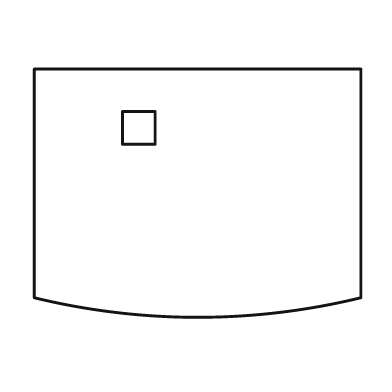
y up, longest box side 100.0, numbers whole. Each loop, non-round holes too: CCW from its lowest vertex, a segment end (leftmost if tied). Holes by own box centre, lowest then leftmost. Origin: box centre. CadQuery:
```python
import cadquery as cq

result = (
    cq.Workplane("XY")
    .moveTo(-50.0, -32.0)
    .threePointArc((0.0, -38.0), (50.0, -32.0))
    .lineTo(50.0, 38.0)
    .lineTo(-50.0, 38.0)
    .close()
    .moveTo(-23.0, 15.0)
    .lineTo(-13.0, 15.0)
    .lineTo(-13.0, 25.0)
    .lineTo(-23.0, 25.0)
    .close()
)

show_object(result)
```